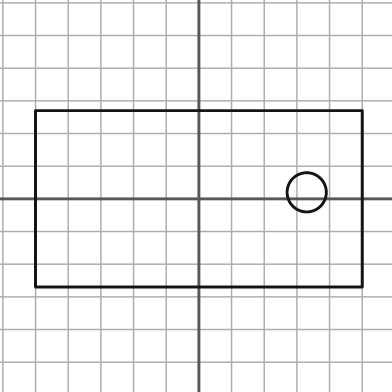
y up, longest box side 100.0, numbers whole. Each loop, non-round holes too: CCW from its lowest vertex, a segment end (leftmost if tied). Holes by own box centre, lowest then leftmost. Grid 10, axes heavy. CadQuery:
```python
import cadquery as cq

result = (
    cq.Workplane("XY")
    .moveTo(-50.0, -27.0)
    .lineTo(50.0, -27.0)
    .lineTo(50.0, 27.0)
    .lineTo(-50.0, 27.0)
    .close()
    .moveTo(33.0, 2.0)
    .circle(6.0)
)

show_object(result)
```